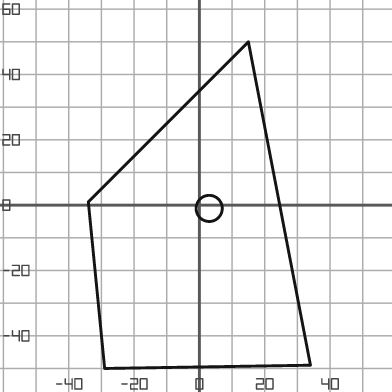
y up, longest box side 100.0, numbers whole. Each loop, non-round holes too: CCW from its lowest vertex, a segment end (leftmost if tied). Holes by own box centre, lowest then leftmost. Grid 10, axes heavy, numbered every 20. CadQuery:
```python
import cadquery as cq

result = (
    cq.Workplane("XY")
    .moveTo(-29.0, -50.0)
    .lineTo(34.0, -49.0)
    .lineTo(15.0, 50.0)
    .lineTo(-34.0, 1.0)
    .close()
    .moveTo(3.0, -1.0)
    .circle(4.0)
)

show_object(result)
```